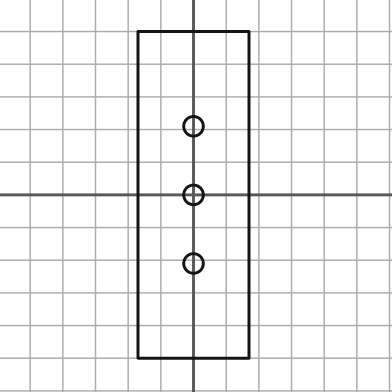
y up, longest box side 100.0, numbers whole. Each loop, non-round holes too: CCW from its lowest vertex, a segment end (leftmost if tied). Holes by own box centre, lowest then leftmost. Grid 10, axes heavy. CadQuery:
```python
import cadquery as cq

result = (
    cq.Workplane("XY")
    .moveTo(-17.0, -50.0)
    .lineTo(17.0, -50.0)
    .lineTo(17.0, 50.0)
    .lineTo(-17.0, 50.0)
    .close()
    .moveTo(0.0, -21.0)
    .circle(3.0)
    .moveTo(0.0, 0.0)
    .circle(3.0)
    .moveTo(0.0, 21.0)
    .circle(3.0)
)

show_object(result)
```